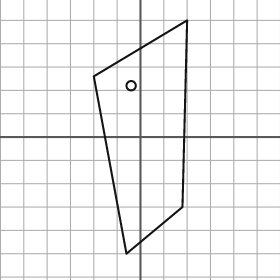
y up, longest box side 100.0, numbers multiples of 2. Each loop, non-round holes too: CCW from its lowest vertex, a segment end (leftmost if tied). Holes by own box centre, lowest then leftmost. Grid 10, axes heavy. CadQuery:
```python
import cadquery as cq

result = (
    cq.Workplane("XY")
    .moveTo(-6.0, -50.0)
    .lineTo(18.0, -30.0)
    .lineTo(20.0, 50.0)
    .lineTo(-20.0, 26.0)
    .close()
    .moveTo(-4.0, 22.0)
    .circle(2.0)
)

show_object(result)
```